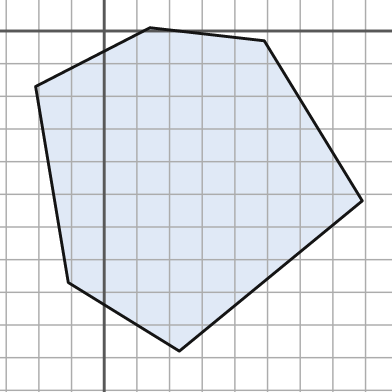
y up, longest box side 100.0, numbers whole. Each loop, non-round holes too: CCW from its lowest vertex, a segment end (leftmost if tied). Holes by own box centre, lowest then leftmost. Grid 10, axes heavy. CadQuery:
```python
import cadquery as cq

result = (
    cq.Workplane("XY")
    .moveTo(23.0, -98.0)
    .lineTo(79.0, -52.0)
    .lineTo(49.0, -3.0)
    .lineTo(14.0, 1.0)
    .lineTo(-21.0, -17.0)
    .lineTo(-11.0, -77.0)
    .close()
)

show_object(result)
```